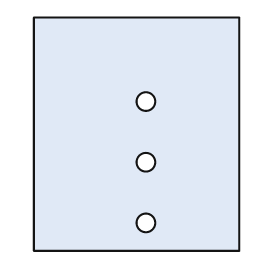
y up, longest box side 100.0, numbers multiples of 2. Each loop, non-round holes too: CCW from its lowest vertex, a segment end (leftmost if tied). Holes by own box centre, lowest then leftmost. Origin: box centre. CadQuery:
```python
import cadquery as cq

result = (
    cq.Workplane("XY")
    .moveTo(-44.0, -50.0)
    .lineTo(44.0, -50.0)
    .lineTo(44.0, 50.0)
    .lineTo(-44.0, 50.0)
    .close()
    .moveTo(4.0, -38.0)
    .circle(4.0)
    .moveTo(4.0, -12.0)
    .circle(4.0)
    .moveTo(4.0, 14.0)
    .circle(4.0)
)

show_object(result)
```